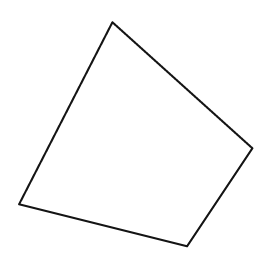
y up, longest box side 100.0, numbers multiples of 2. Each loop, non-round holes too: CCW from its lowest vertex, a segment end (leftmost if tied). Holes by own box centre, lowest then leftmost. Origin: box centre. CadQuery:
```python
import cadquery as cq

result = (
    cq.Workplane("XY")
    .moveTo(22.0, -48.0)
    .lineTo(50.0, -6.0)
    .lineTo(-10.0, 48.0)
    .lineTo(-50.0, -30.0)
    .close()
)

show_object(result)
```